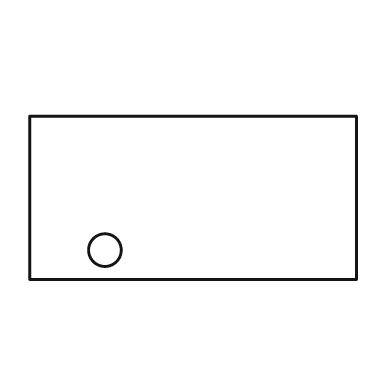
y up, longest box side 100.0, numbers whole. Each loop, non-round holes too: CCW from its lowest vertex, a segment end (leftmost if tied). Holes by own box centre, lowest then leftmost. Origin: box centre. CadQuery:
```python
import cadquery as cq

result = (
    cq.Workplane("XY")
    .moveTo(-50.0, -25.0)
    .lineTo(50.0, -25.0)
    .lineTo(50.0, 25.0)
    .lineTo(-50.0, 25.0)
    .close()
    .moveTo(-27.0, -16.0)
    .circle(5.0)
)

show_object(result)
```